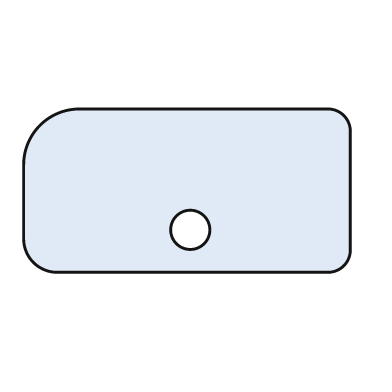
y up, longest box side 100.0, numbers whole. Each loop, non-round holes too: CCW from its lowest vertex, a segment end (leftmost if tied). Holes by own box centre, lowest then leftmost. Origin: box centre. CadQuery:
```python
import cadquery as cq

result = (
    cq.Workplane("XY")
    .moveTo(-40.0, -25.0)
    .lineTo(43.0, -25.0)
    .threePointArc((48.0, -23.0), (50.0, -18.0))
    .lineTo(50.0, 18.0)
    .threePointArc((48.0, 23.0), (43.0, 25.0))
    .lineTo(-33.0, 25.0)
    .threePointArc((-45.0, 20.0), (-50.0, 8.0))
    .lineTo(-50.0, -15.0)
    .threePointArc((-47.0, -22.0), (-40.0, -25.0))
    .close()
    .moveTo(1.0, -12.0)
    .circle(6.0)
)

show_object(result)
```